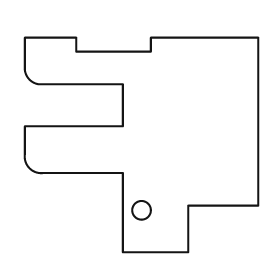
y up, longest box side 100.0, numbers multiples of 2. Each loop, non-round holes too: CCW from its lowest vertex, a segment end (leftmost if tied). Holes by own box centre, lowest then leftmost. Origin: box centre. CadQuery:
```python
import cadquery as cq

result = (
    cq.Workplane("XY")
    .moveTo(-8.0, -46.0)
    .lineTo(20.0, -46.0)
    .lineTo(20.0, -26.0)
    .lineTo(50.0, -26.0)
    .lineTo(50.0, 46.0)
    .lineTo(4.0, 46.0)
    .lineTo(4.0, 40.0)
    .lineTo(-28.0, 40.0)
    .lineTo(-28.0, 46.0)
    .lineTo(-50.0, 46.0)
    .lineTo(-50.0, 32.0)
    .threePointArc((-48.0, 28.0), (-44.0, 26.0))
    .lineTo(-8.0, 26.0)
    .lineTo(-8.0, 8.0)
    .lineTo(-50.0, 8.0)
    .lineTo(-50.0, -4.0)
    .threePointArc((-48.0, -10.0), (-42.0, -12.0))
    .lineTo(-8.0, -12.0)
    .close()
    .moveTo(0.0, -28.0)
    .circle(4.0)
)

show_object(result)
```